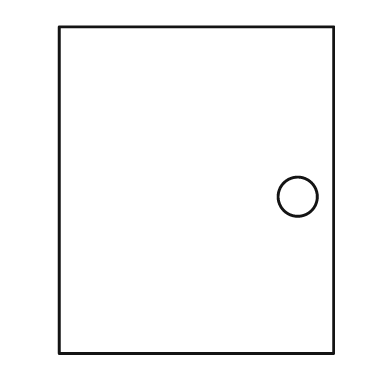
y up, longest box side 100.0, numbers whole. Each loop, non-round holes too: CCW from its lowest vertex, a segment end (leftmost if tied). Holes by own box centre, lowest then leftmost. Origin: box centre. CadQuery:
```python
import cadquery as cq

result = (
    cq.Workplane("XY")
    .moveTo(-42.0, -50.0)
    .lineTo(42.0, -50.0)
    .lineTo(42.0, 50.0)
    .lineTo(-42.0, 50.0)
    .close()
    .moveTo(31.0, -2.0)
    .circle(6.0)
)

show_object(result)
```